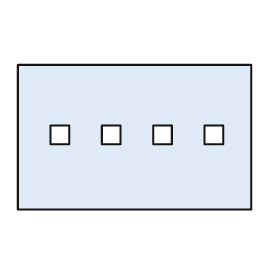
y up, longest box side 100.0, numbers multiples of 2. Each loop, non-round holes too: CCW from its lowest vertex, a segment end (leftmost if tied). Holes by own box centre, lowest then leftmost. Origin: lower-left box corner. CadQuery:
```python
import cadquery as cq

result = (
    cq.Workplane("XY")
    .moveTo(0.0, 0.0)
    .lineTo(100.0, 0.0)
    .lineTo(100.0, 62.0)
    .lineTo(0.0, 62.0)
    .close()
    .moveTo(14.0, 28.0)
    .lineTo(22.0, 28.0)
    .lineTo(22.0, 36.0)
    .lineTo(14.0, 36.0)
    .close()
    .moveTo(36.0, 28.0)
    .lineTo(44.0, 28.0)
    .lineTo(44.0, 36.0)
    .lineTo(36.0, 36.0)
    .close()
    .moveTo(58.0, 28.0)
    .lineTo(66.0, 28.0)
    .lineTo(66.0, 36.0)
    .lineTo(58.0, 36.0)
    .close()
    .moveTo(80.0, 28.0)
    .lineTo(88.0, 28.0)
    .lineTo(88.0, 36.0)
    .lineTo(80.0, 36.0)
    .close()
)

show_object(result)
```